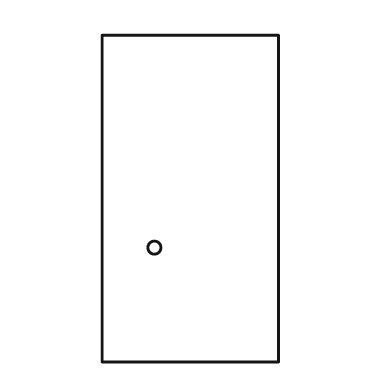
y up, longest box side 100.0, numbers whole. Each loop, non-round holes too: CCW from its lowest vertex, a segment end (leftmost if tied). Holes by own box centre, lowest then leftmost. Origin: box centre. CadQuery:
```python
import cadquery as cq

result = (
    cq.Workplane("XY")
    .moveTo(-27.0, -50.0)
    .lineTo(27.0, -50.0)
    .lineTo(27.0, 50.0)
    .lineTo(-27.0, 50.0)
    .close()
    .moveTo(-11.0, -15.0)
    .circle(2.0)
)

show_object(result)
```